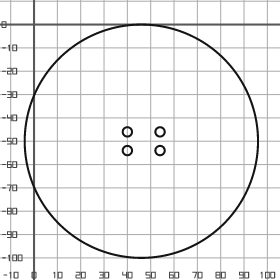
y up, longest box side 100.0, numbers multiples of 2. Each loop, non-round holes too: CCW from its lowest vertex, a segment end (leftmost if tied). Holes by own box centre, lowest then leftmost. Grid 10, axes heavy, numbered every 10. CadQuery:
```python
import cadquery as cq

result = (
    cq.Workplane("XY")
    .moveTo(46.0, -50.0)
    .circle(50.0)
    .moveTo(40.0, -54.0)
    .circle(2.0)
    .moveTo(54.0, -54.0)
    .circle(2.0)
    .moveTo(40.0, -46.0)
    .circle(2.0)
    .moveTo(54.0, -46.0)
    .circle(2.0)
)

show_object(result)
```